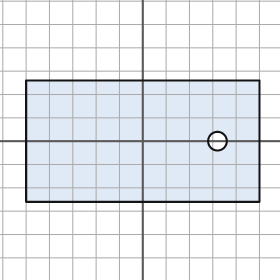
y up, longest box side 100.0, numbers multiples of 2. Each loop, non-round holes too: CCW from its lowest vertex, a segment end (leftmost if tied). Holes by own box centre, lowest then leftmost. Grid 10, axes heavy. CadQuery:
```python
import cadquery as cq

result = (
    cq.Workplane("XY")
    .moveTo(-50.0, -26.0)
    .lineTo(50.0, -26.0)
    .lineTo(50.0, 26.0)
    .lineTo(-50.0, 26.0)
    .close()
    .moveTo(32.0, 0.0)
    .circle(4.0)
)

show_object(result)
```